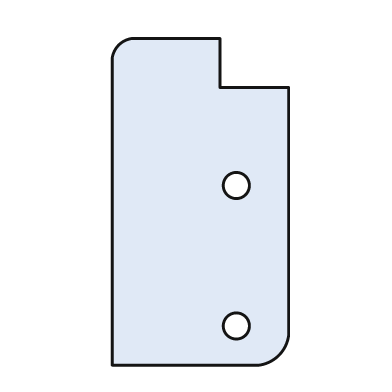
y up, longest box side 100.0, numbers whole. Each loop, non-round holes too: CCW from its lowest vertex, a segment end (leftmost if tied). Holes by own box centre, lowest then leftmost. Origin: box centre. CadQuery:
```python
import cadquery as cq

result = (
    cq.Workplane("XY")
    .moveTo(-27.0, -50.0)
    .lineTo(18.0, -50.0)
    .threePointArc((24.0, -47.0), (27.0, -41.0))
    .lineTo(27.0, 35.0)
    .lineTo(6.0, 35.0)
    .lineTo(6.0, 50.0)
    .lineTo(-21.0, 50.0)
    .threePointArc((-25.0, 48.0), (-27.0, 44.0))
    .close()
    .moveTo(11.0, -38.0)
    .circle(4.0)
    .moveTo(11.0, 5.0)
    .circle(4.0)
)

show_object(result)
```